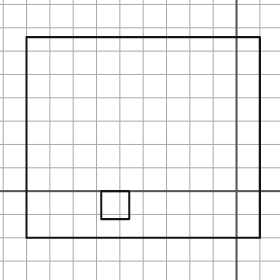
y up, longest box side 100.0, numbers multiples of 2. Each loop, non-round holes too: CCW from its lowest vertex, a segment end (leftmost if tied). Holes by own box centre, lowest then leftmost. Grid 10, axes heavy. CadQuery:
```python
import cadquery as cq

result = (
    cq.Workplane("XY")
    .moveTo(-90.0, -20.0)
    .lineTo(10.0, -20.0)
    .lineTo(10.0, 66.0)
    .lineTo(-90.0, 66.0)
    .close()
    .moveTo(-58.0, -12.0)
    .lineTo(-46.0, -12.0)
    .lineTo(-46.0, 0.0)
    .lineTo(-58.0, 0.0)
    .close()
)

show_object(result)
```